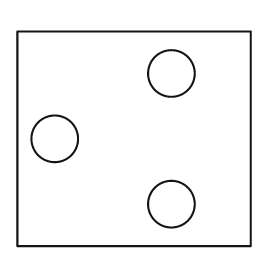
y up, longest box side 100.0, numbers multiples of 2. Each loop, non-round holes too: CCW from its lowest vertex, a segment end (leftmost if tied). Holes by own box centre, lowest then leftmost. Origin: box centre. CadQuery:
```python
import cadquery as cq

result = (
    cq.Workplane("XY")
    .moveTo(-50.0, -46.0)
    .lineTo(50.0, -46.0)
    .lineTo(50.0, 46.0)
    .lineTo(-50.0, 46.0)
    .close()
    .moveTo(16.0, -28.0)
    .circle(10.0)
    .moveTo(-34.0, 0.0)
    .circle(10.0)
    .moveTo(16.0, 28.0)
    .circle(10.0)
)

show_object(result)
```